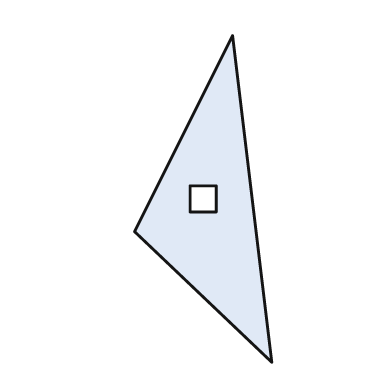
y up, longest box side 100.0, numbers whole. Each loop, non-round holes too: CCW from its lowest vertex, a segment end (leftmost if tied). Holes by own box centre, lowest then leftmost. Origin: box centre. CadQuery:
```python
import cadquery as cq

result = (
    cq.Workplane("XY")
    .moveTo(21.0, -50.0)
    .lineTo(9.0, 50.0)
    .lineTo(-21.0, -10.0)
    .close()
    .moveTo(-4.0, -4.0)
    .lineTo(4.0, -4.0)
    .lineTo(4.0, 4.0)
    .lineTo(-4.0, 4.0)
    .close()
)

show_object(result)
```